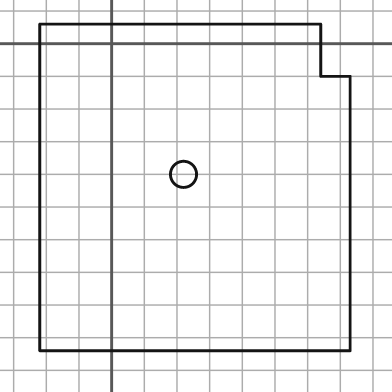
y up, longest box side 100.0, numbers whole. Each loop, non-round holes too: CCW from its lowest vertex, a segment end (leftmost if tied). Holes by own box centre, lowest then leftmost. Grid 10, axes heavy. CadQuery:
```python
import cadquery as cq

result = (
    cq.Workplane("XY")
    .moveTo(-22.0, -94.0)
    .lineTo(73.0, -94.0)
    .lineTo(73.0, -10.0)
    .lineTo(64.0, -10.0)
    .lineTo(64.0, 6.0)
    .lineTo(-22.0, 6.0)
    .close()
    .moveTo(22.0, -40.0)
    .circle(4.0)
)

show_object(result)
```